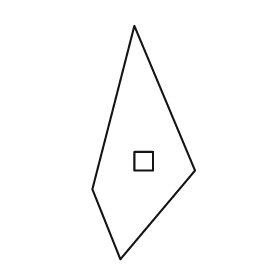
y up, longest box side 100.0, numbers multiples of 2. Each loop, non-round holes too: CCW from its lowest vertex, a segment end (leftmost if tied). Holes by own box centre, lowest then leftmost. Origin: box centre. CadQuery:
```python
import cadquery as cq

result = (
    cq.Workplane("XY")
    .moveTo(-10.0, -50.0)
    .lineTo(22.0, -12.0)
    .lineTo(-4.0, 50.0)
    .lineTo(-22.0, -20.0)
    .close()
    .moveTo(-4.0, -12.0)
    .lineTo(4.0, -12.0)
    .lineTo(4.0, -4.0)
    .lineTo(-4.0, -4.0)
    .close()
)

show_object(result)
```